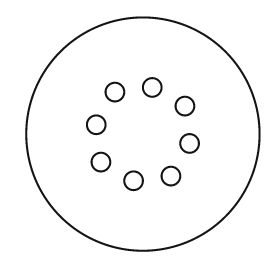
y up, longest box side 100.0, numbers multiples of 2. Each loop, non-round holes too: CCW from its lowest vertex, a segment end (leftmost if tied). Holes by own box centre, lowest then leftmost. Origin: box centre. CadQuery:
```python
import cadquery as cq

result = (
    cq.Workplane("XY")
    .moveTo(0.0, 0.0)
    .circle(50.0)
    .moveTo(-4.0, -20.0)
    .circle(4.0)
    .moveTo(12.0, -18.0)
    .circle(4.0)
    .moveTo(-18.0, -12.0)
    .circle(4.0)
    .moveTo(20.0, -4.0)
    .circle(4.0)
    .moveTo(-20.0, 4.0)
    .circle(4.0)
    .moveTo(18.0, 12.0)
    .circle(4.0)
    .moveTo(-12.0, 18.0)
    .circle(4.0)
    .moveTo(4.0, 20.0)
    .circle(4.0)
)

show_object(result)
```